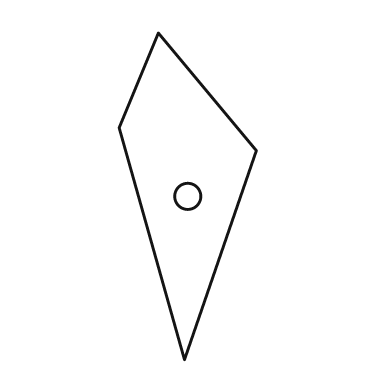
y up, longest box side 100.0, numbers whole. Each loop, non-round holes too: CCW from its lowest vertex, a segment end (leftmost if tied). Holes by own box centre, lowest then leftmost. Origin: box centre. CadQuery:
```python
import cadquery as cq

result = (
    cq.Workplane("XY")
    .moveTo(-1.0, -50.0)
    .lineTo(21.0, 14.0)
    .lineTo(-9.0, 50.0)
    .lineTo(-21.0, 21.0)
    .close()
    .moveTo(0.0, 0.0)
    .circle(4.0)
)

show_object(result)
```